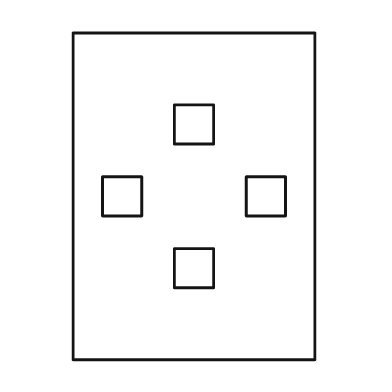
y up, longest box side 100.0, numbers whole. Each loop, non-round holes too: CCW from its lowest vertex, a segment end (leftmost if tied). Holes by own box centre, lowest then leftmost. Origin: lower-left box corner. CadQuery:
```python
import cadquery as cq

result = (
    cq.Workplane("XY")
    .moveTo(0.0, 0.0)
    .lineTo(74.0, 0.0)
    .lineTo(74.0, 100.0)
    .lineTo(0.0, 100.0)
    .close()
    .moveTo(31.0, 22.0)
    .lineTo(43.0, 22.0)
    .lineTo(43.0, 34.0)
    .lineTo(31.0, 34.0)
    .close()
    .moveTo(9.0, 44.0)
    .lineTo(21.0, 44.0)
    .lineTo(21.0, 56.0)
    .lineTo(9.0, 56.0)
    .close()
    .moveTo(53.0, 44.0)
    .lineTo(65.0, 44.0)
    .lineTo(65.0, 56.0)
    .lineTo(53.0, 56.0)
    .close()
    .moveTo(31.0, 66.0)
    .lineTo(43.0, 66.0)
    .lineTo(43.0, 78.0)
    .lineTo(31.0, 78.0)
    .close()
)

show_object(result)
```